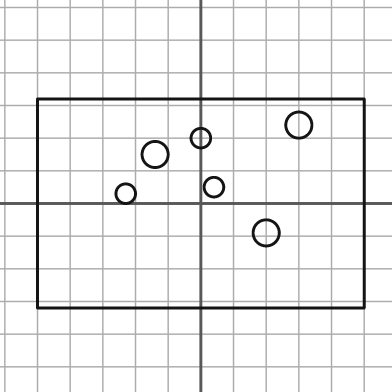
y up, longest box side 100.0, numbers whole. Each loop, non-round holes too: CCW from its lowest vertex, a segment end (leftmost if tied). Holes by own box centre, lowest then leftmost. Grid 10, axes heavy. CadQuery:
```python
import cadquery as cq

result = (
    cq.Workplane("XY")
    .moveTo(-50.0, -32.0)
    .lineTo(50.0, -32.0)
    .lineTo(50.0, 32.0)
    .lineTo(-50.0, 32.0)
    .close()
    .moveTo(20.0, -9.0)
    .circle(4.0)
    .moveTo(-23.0, 3.0)
    .circle(3.0)
    .moveTo(4.0, 5.0)
    .circle(3.0)
    .moveTo(-14.0, 15.0)
    .circle(4.0)
    .moveTo(0.0, 20.0)
    .circle(3.0)
    .moveTo(30.0, 24.0)
    .circle(4.0)
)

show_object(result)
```